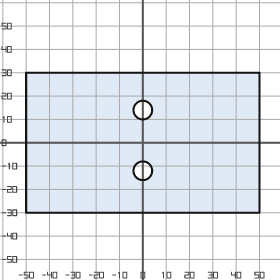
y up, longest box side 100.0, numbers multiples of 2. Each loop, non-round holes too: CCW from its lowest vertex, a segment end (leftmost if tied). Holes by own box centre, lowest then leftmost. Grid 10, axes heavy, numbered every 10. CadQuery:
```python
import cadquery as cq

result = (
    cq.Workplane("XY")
    .moveTo(-50.0, -30.0)
    .lineTo(50.0, -30.0)
    .lineTo(50.0, 30.0)
    .lineTo(-50.0, 30.0)
    .close()
    .moveTo(0.0, -12.0)
    .circle(4.0)
    .moveTo(0.0, 14.0)
    .circle(4.0)
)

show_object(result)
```